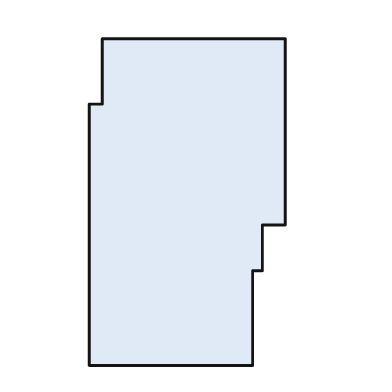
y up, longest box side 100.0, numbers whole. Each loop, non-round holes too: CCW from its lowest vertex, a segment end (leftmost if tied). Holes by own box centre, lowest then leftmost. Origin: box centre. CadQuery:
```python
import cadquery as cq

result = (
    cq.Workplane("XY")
    .moveTo(-30.0, -50.0)
    .lineTo(20.0, -50.0)
    .lineTo(20.0, -21.0)
    .lineTo(23.0, -21.0)
    .lineTo(23.0, -7.0)
    .lineTo(30.0, -7.0)
    .lineTo(30.0, 50.0)
    .lineTo(-26.0, 50.0)
    .lineTo(-26.0, 30.0)
    .lineTo(-30.0, 30.0)
    .close()
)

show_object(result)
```